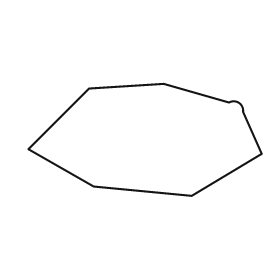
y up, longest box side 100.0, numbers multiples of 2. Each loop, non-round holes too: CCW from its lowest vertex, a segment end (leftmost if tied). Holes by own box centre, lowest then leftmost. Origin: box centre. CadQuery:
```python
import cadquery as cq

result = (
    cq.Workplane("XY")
    .moveTo(20.0, -24.0)
    .lineTo(50.0, -6.0)
    .lineTo(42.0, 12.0)
    .threePointArc((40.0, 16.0), (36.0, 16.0))
    .lineTo(8.0, 24.0)
    .lineTo(-24.0, 22.0)
    .lineTo(-50.0, -4.0)
    .lineTo(-22.0, -20.0)
    .close()
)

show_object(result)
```